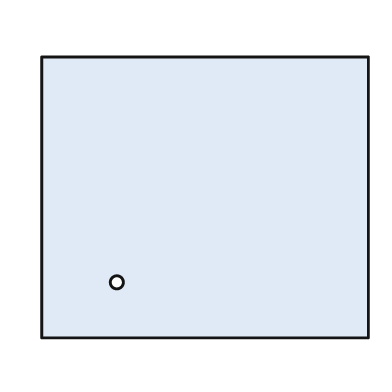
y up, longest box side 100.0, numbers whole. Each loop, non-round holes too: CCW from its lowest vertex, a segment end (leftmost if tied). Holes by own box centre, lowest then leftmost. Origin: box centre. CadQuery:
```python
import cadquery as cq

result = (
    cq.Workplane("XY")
    .moveTo(-50.0, -43.0)
    .lineTo(50.0, -43.0)
    .lineTo(50.0, 43.0)
    .lineTo(-50.0, 43.0)
    .close()
    .moveTo(-27.0, -26.0)
    .circle(2.0)
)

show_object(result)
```